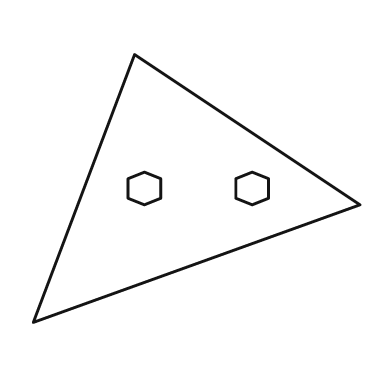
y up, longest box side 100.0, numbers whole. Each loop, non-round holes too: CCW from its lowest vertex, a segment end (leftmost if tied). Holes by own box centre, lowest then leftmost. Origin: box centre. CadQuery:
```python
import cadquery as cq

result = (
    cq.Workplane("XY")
    .moveTo(-50.0, -41.0)
    .lineTo(50.0, -5.0)
    .lineTo(-19.0, 41.0)
    .close()
    .moveTo(-16.0, -5.0)
    .lineTo(-11.0, -3.0)
    .lineTo(-11.0, 3.0)
    .lineTo(-16.0, 5.0)
    .lineTo(-21.0, 3.0)
    .lineTo(-21.0, -3.0)
    .close()
    .moveTo(17.0, -5.0)
    .lineTo(22.0, -3.0)
    .lineTo(22.0, 3.0)
    .lineTo(17.0, 5.0)
    .lineTo(12.0, 3.0)
    .lineTo(12.0, -3.0)
    .close()
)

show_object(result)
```